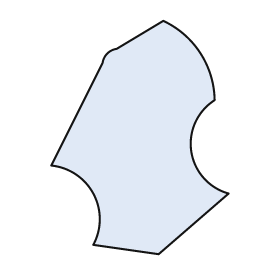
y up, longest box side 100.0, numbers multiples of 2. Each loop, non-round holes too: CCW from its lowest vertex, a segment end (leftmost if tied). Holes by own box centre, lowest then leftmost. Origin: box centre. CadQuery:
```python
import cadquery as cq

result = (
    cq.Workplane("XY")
    .moveTo(8.0, -50.0)
    .lineTo(38.0, -24.0)
    .threePointArc((22.0, -6.0), (32.0, 16.0))
    .threePointArc((26.0, 36.0), (10.0, 50.0))
    .lineTo(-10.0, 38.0)
    .threePointArc((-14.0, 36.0), (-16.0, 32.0))
    .lineTo(-38.0, -12.0)
    .threePointArc((-20.0, -24.0), (-20.0, -46.0))
    .close()
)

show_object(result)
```